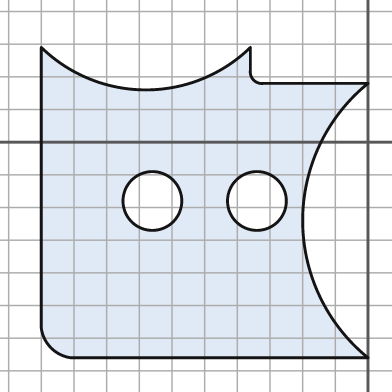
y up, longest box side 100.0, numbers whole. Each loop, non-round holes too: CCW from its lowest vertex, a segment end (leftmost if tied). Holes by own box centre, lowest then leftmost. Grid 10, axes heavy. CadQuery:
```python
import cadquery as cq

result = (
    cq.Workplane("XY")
    .moveTo(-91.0, -66.0)
    .lineTo(0.0, -66.0)
    .threePointArc((-20.0, -24.0), (0.0, 18.0))
    .lineTo(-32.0, 18.0)
    .threePointArc((-35.0, 19.0), (-36.0, 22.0))
    .lineTo(-36.0, 29.0)
    .threePointArc((-68.0, 16.0), (-100.0, 29.0))
    .lineTo(-100.0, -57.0)
    .threePointArc((-97.0, -63.0), (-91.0, -66.0))
    .close()
    .moveTo(-66.0, -18.0)
    .circle(9.0)
    .moveTo(-34.0, -18.0)
    .circle(9.0)
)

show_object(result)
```